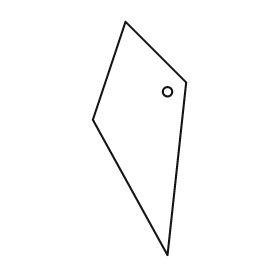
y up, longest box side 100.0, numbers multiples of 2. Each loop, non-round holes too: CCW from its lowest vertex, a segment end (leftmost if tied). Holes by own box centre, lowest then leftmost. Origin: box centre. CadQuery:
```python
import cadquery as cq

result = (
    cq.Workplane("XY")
    .moveTo(12.0, -50.0)
    .lineTo(20.0, 24.0)
    .lineTo(-6.0, 50.0)
    .lineTo(-20.0, 8.0)
    .close()
    .moveTo(12.0, 20.0)
    .circle(2.0)
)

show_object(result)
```